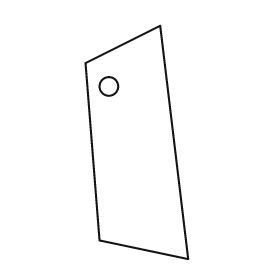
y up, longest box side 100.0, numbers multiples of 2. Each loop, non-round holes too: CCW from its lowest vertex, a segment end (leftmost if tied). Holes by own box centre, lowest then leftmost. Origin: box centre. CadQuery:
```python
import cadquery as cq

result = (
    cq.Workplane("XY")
    .moveTo(22.0, -50.0)
    .lineTo(10.0, 50.0)
    .lineTo(-22.0, 34.0)
    .lineTo(-16.0, -42.0)
    .close()
    .moveTo(-12.0, 24.0)
    .circle(4.0)
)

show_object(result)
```